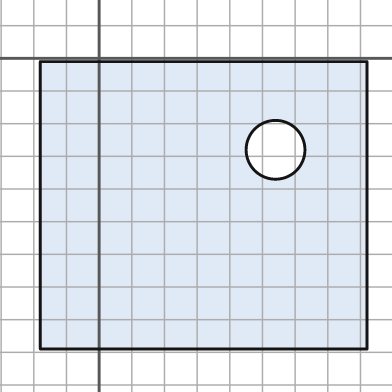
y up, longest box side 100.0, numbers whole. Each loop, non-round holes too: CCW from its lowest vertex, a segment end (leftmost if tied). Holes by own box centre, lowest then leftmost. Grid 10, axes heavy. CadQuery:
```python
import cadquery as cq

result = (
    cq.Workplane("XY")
    .moveTo(-18.0, -89.0)
    .lineTo(82.0, -89.0)
    .lineTo(82.0, -1.0)
    .lineTo(-18.0, -1.0)
    .close()
    .moveTo(54.0, -28.0)
    .circle(9.0)
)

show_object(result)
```